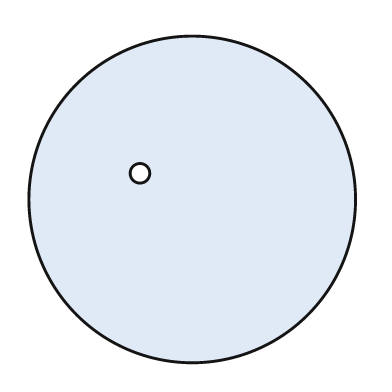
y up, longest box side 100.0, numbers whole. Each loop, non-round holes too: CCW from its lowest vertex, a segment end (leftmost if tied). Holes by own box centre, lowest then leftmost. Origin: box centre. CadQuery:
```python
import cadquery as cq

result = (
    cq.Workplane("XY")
    .moveTo(0.0, 0.0)
    .circle(50.0)
    .moveTo(-16.0, 8.0)
    .circle(3.0)
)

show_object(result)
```